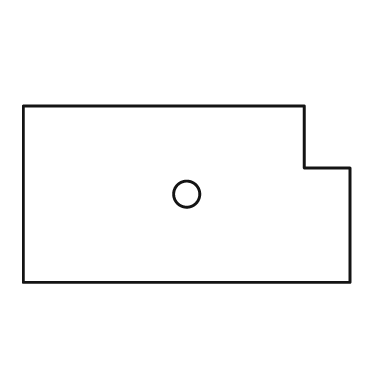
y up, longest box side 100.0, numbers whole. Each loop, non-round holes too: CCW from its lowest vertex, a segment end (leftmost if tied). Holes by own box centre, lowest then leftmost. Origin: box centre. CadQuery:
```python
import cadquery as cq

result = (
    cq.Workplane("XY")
    .moveTo(-50.0, -27.0)
    .lineTo(50.0, -27.0)
    .lineTo(50.0, 8.0)
    .lineTo(36.0, 8.0)
    .lineTo(36.0, 27.0)
    .lineTo(-50.0, 27.0)
    .close()
    .moveTo(0.0, 0.0)
    .circle(4.0)
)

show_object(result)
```